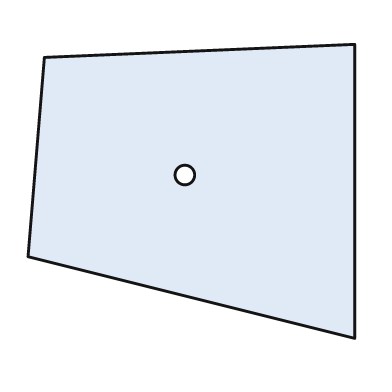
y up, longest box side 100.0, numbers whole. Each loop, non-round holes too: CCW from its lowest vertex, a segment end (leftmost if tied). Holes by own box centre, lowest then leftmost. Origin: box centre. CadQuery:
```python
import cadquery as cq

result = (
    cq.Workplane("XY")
    .moveTo(50.0, -45.0)
    .lineTo(50.0, 45.0)
    .lineTo(-45.0, 41.0)
    .lineTo(-50.0, -20.0)
    .close()
    .moveTo(-2.0, 5.0)
    .circle(3.0)
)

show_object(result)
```